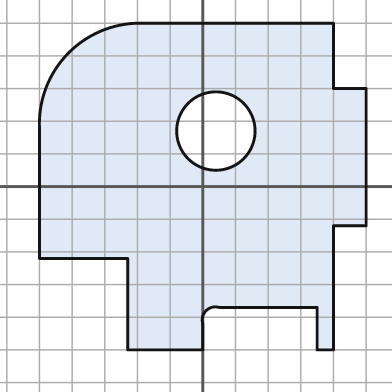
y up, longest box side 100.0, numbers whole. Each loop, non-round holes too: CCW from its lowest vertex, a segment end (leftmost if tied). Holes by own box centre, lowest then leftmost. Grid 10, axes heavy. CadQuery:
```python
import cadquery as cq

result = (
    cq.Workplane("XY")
    .moveTo(-23.0, -50.0)
    .lineTo(0.0, -50.0)
    .lineTo(0.0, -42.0)
    .threePointArc((1.0, -38.0), (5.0, -37.0))
    .lineTo(35.0, -37.0)
    .lineTo(35.0, -50.0)
    .lineTo(40.0, -50.0)
    .lineTo(40.0, -12.0)
    .lineTo(50.0, -12.0)
    .lineTo(50.0, 30.0)
    .lineTo(40.0, 30.0)
    .lineTo(40.0, 50.0)
    .lineTo(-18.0, 50.0)
    .threePointArc((-41.0, 41.0), (-50.0, 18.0))
    .lineTo(-50.0, -22.0)
    .lineTo(-23.0, -22.0)
    .close()
    .moveTo(4.0, 17.0)
    .circle(12.0)
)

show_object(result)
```